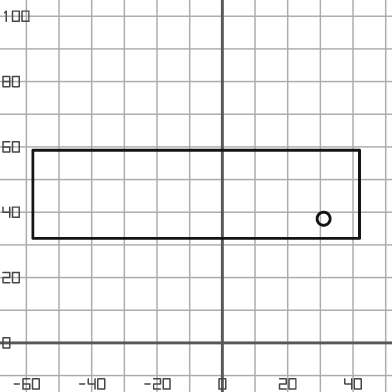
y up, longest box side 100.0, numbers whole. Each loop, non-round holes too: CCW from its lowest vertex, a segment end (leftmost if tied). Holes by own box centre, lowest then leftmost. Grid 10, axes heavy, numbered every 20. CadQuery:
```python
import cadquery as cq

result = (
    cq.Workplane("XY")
    .moveTo(-58.0, 32.0)
    .lineTo(42.0, 32.0)
    .lineTo(42.0, 59.0)
    .lineTo(-58.0, 59.0)
    .close()
    .moveTo(31.0, 38.0)
    .circle(2.0)
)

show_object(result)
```